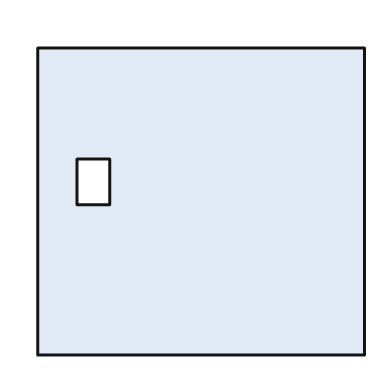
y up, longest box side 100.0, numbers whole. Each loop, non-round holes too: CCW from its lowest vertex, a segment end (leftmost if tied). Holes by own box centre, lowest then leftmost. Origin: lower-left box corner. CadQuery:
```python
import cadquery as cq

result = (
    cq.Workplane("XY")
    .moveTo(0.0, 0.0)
    .lineTo(100.0, 0.0)
    .lineTo(100.0, 94.0)
    .lineTo(0.0, 94.0)
    .close()
    .moveTo(12.0, 46.0)
    .lineTo(22.0, 46.0)
    .lineTo(22.0, 60.0)
    .lineTo(12.0, 60.0)
    .close()
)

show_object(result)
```